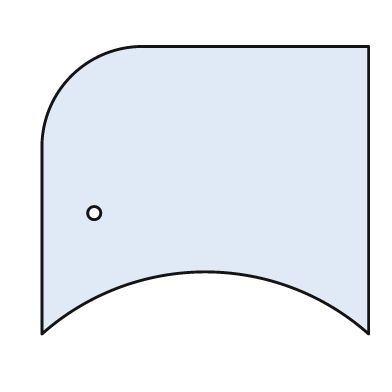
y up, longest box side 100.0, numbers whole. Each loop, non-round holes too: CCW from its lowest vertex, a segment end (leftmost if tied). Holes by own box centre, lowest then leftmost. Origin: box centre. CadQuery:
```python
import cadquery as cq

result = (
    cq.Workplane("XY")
    .moveTo(-50.0, -44.0)
    .threePointArc((0.0, -25.0), (50.0, -44.0))
    .lineTo(50.0, 44.0)
    .lineTo(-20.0, 44.0)
    .threePointArc((-41.0, 35.0), (-50.0, 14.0))
    .close()
    .moveTo(-34.0, -7.0)
    .circle(2.0)
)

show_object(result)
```